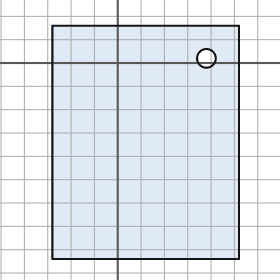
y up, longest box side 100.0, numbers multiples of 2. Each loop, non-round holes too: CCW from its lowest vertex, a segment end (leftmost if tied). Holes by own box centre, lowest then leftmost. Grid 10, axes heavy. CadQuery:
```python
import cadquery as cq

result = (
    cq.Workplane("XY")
    .moveTo(-28.0, -84.0)
    .lineTo(52.0, -84.0)
    .lineTo(52.0, 16.0)
    .lineTo(-28.0, 16.0)
    .close()
    .moveTo(38.0, 2.0)
    .circle(4.0)
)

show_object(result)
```